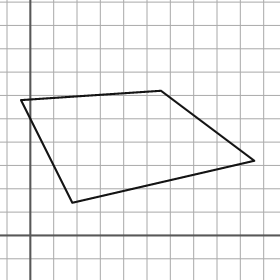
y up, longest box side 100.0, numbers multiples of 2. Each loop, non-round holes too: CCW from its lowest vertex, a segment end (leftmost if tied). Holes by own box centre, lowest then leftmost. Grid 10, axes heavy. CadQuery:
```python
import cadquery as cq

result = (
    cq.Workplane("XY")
    .moveTo(18.0, 14.0)
    .lineTo(96.0, 32.0)
    .lineTo(56.0, 62.0)
    .lineTo(-4.0, 58.0)
    .close()
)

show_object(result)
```